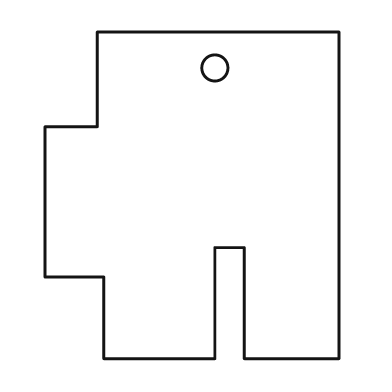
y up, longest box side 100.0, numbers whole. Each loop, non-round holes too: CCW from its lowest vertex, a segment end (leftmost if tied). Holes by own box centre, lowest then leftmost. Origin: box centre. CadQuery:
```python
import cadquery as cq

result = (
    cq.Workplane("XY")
    .moveTo(-27.0, -50.0)
    .lineTo(7.0, -50.0)
    .lineTo(7.0, -16.0)
    .lineTo(16.0, -16.0)
    .lineTo(16.0, -50.0)
    .lineTo(45.0, -50.0)
    .lineTo(45.0, 50.0)
    .lineTo(-29.0, 50.0)
    .lineTo(-29.0, 21.0)
    .lineTo(-45.0, 21.0)
    .lineTo(-45.0, -25.0)
    .lineTo(-27.0, -25.0)
    .close()
    .moveTo(7.0, 39.0)
    .circle(4.0)
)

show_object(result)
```